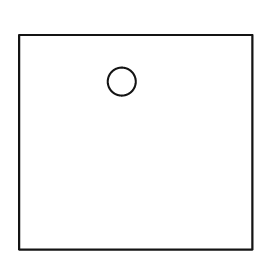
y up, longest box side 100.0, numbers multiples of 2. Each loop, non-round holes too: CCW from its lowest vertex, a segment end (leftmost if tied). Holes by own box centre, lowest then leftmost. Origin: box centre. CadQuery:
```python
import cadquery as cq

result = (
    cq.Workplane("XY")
    .moveTo(-50.0, -46.0)
    .lineTo(50.0, -46.0)
    .lineTo(50.0, 46.0)
    .lineTo(-50.0, 46.0)
    .close()
    .moveTo(-6.0, 26.0)
    .circle(6.0)
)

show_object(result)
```